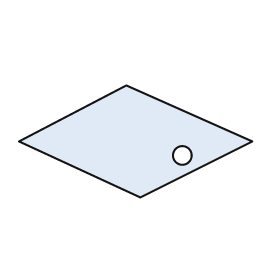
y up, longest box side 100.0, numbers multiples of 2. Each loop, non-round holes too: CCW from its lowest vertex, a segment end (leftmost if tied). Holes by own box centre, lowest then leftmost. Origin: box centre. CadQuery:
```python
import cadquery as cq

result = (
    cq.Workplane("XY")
    .moveTo(2.0, -24.0)
    .lineTo(50.0, 0.0)
    .lineTo(-4.0, 24.0)
    .lineTo(-50.0, 0.0)
    .close()
    .moveTo(20.0, -6.0)
    .circle(4.0)
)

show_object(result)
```